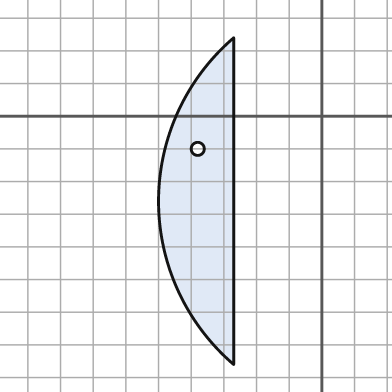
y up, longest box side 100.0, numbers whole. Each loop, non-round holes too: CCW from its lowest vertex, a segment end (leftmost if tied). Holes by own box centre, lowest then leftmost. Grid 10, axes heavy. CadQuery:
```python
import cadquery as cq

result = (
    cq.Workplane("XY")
    .moveTo(-27.0, -76.0)
    .lineTo(-27.0, 24.0)
    .threePointArc((-50.0, -26.0), (-27.0, -76.0))
    .close()
    .moveTo(-38.0, -10.0)
    .circle(2.0)
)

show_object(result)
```